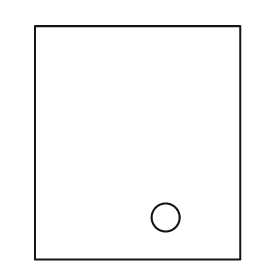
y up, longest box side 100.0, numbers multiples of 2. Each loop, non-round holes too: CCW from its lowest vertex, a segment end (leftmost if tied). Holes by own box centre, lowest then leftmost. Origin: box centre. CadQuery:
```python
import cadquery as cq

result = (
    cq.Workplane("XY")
    .moveTo(-44.0, -50.0)
    .lineTo(44.0, -50.0)
    .lineTo(44.0, 50.0)
    .lineTo(-44.0, 50.0)
    .close()
    .moveTo(12.0, -32.0)
    .circle(6.0)
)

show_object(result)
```